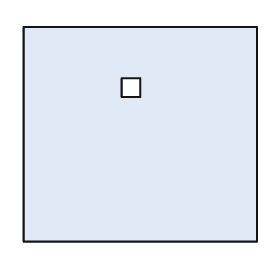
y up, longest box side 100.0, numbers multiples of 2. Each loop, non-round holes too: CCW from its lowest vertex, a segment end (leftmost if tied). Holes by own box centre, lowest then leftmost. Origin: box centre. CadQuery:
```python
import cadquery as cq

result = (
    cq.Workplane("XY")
    .moveTo(-50.0, -46.0)
    .lineTo(50.0, -46.0)
    .lineTo(50.0, 46.0)
    .lineTo(-50.0, 46.0)
    .close()
    .moveTo(-8.0, 16.0)
    .lineTo(0.0, 16.0)
    .lineTo(0.0, 24.0)
    .lineTo(-8.0, 24.0)
    .close()
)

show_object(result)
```